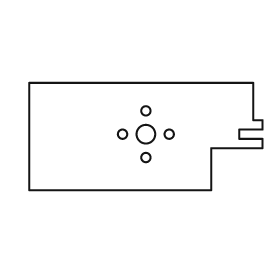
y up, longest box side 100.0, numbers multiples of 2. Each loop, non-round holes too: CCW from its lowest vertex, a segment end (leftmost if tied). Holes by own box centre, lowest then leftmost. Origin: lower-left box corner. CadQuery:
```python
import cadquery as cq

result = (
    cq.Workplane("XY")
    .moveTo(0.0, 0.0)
    .lineTo(78.0, 0.0)
    .lineTo(78.0, 18.0)
    .lineTo(100.0, 18.0)
    .lineTo(100.0, 22.0)
    .lineTo(90.0, 22.0)
    .lineTo(90.0, 26.0)
    .lineTo(100.0, 26.0)
    .lineTo(100.0, 30.0)
    .lineTo(96.0, 30.0)
    .lineTo(96.0, 46.0)
    .lineTo(0.0, 46.0)
    .close()
    .moveTo(50.0, 14.0)
    .circle(2.0)
    .moveTo(40.0, 24.0)
    .circle(2.0)
    .moveTo(50.0, 24.0)
    .circle(4.0)
    .moveTo(60.0, 24.0)
    .circle(2.0)
    .moveTo(50.0, 34.0)
    .circle(2.0)
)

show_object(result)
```